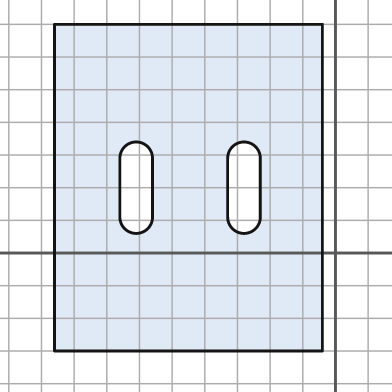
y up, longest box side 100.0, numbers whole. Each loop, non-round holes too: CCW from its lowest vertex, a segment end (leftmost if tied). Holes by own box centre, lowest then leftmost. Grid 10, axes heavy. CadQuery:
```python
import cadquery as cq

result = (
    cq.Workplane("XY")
    .moveTo(-86.0, -30.0)
    .lineTo(-4.0, -30.0)
    .lineTo(-4.0, 70.0)
    .lineTo(-86.0, 70.0)
    .close()
    .moveTo(-66.0, 11.0)
    .threePointArc((-61.0, 6.0), (-56.0, 11.0))
    .lineTo(-56.0, 29.0)
    .threePointArc((-61.0, 34.0), (-66.0, 29.0))
    .close()
    .moveTo(-33.0, 11.0)
    .threePointArc((-28.0, 6.0), (-23.0, 11.0))
    .lineTo(-23.0, 29.0)
    .threePointArc((-28.0, 34.0), (-33.0, 29.0))
    .close()
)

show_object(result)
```